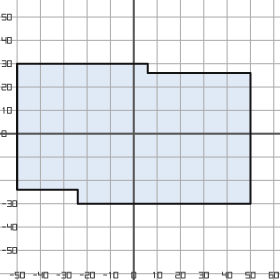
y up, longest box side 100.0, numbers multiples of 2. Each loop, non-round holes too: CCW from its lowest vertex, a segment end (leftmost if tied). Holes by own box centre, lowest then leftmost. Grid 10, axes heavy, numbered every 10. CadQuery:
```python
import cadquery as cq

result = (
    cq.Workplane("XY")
    .moveTo(-24.0, -30.0)
    .lineTo(50.0, -30.0)
    .lineTo(50.0, 26.0)
    .lineTo(6.0, 26.0)
    .lineTo(6.0, 30.0)
    .lineTo(-50.0, 30.0)
    .lineTo(-50.0, -24.0)
    .lineTo(-24.0, -24.0)
    .close()
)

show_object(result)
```